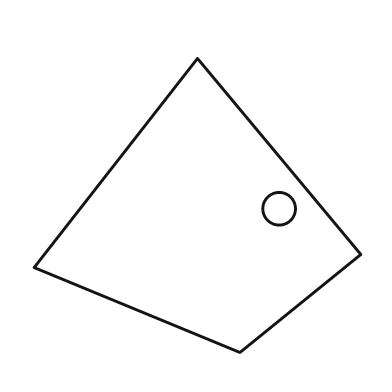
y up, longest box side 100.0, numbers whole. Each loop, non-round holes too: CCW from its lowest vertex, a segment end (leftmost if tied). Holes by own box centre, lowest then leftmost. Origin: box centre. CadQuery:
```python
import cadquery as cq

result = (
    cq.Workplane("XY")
    .moveTo(13.0, -45.0)
    .lineTo(50.0, -15.0)
    .lineTo(0.0, 45.0)
    .lineTo(-50.0, -19.0)
    .close()
    .moveTo(25.0, -1.0)
    .circle(5.0)
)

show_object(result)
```